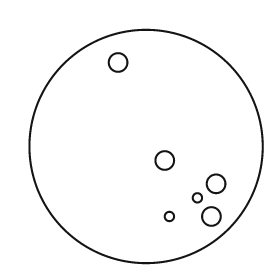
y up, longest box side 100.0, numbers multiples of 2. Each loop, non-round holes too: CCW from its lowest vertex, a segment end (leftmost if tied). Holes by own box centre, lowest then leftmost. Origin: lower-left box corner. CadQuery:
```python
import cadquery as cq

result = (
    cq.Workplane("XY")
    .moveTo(50.0, 50.0)
    .circle(50.0)
    .moveTo(60.0, 20.0)
    .circle(2.0)
    .moveTo(78.0, 20.0)
    .circle(4.0)
    .moveTo(72.0, 28.0)
    .circle(2.0)
    .moveTo(80.0, 34.0)
    .circle(4.0)
    .moveTo(58.0, 44.0)
    .circle(4.0)
    .moveTo(38.0, 86.0)
    .circle(4.0)
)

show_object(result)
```